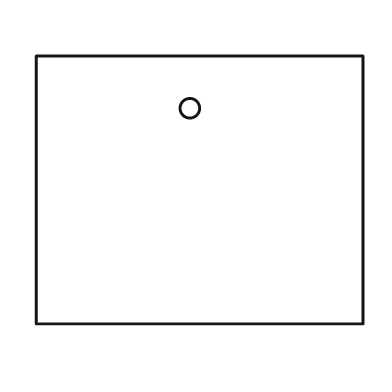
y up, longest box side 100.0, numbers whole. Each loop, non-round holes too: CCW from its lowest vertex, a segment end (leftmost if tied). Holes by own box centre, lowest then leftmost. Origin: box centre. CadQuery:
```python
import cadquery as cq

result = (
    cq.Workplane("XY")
    .moveTo(-50.0, -41.0)
    .lineTo(50.0, -41.0)
    .lineTo(50.0, 41.0)
    .lineTo(-50.0, 41.0)
    .close()
    .moveTo(-3.0, 25.0)
    .circle(3.0)
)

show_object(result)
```